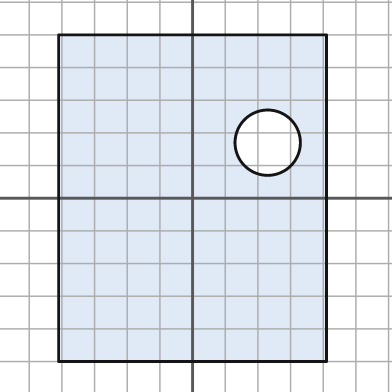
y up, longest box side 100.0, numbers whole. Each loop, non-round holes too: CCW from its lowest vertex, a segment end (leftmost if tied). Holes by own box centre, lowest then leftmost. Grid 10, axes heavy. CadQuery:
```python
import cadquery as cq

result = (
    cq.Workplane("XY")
    .moveTo(-41.0, -50.0)
    .lineTo(41.0, -50.0)
    .lineTo(41.0, 50.0)
    .lineTo(-41.0, 50.0)
    .close()
    .moveTo(23.0, 17.0)
    .circle(10.0)
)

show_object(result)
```